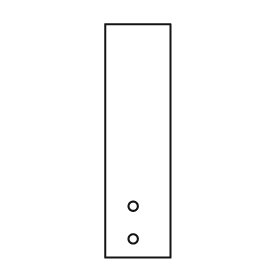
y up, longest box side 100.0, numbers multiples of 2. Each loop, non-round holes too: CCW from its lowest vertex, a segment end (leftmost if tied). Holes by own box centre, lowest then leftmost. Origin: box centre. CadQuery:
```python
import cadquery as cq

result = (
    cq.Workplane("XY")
    .moveTo(-14.0, -50.0)
    .lineTo(14.0, -50.0)
    .lineTo(14.0, 50.0)
    .lineTo(-14.0, 50.0)
    .close()
    .moveTo(-2.0, -42.0)
    .circle(2.0)
    .moveTo(-2.0, -28.0)
    .circle(2.0)
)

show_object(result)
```